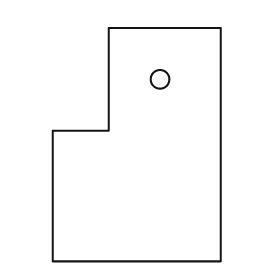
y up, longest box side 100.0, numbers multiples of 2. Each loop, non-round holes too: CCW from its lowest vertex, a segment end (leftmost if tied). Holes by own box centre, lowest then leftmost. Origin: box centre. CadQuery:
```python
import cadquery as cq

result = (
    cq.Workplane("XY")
    .moveTo(-36.0, -50.0)
    .lineTo(36.0, -50.0)
    .lineTo(36.0, 50.0)
    .lineTo(-12.0, 50.0)
    .lineTo(-12.0, 6.0)
    .lineTo(-36.0, 6.0)
    .close()
    .moveTo(10.0, 28.0)
    .circle(4.0)
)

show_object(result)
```